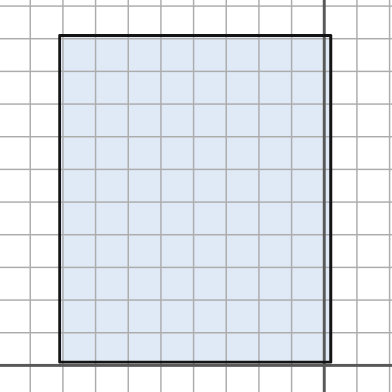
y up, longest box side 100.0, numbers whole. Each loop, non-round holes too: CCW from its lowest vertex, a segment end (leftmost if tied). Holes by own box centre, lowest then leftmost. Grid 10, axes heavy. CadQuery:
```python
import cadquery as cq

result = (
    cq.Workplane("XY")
    .moveTo(-81.0, 1.0)
    .lineTo(2.0, 1.0)
    .lineTo(2.0, 101.0)
    .lineTo(-81.0, 101.0)
    .close()
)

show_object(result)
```